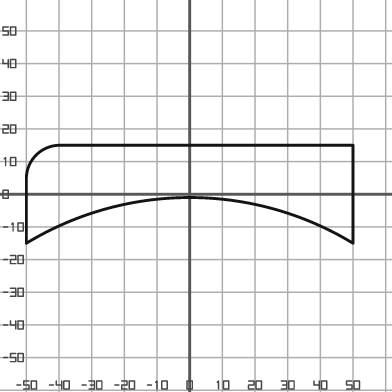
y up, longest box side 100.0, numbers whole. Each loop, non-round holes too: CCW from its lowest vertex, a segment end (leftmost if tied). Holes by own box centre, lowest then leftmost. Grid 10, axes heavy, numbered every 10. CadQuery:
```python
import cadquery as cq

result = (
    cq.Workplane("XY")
    .moveTo(-50.0, -15.0)
    .threePointArc((0.0, -1.0), (50.0, -15.0))
    .lineTo(50.0, 15.0)
    .lineTo(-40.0, 15.0)
    .threePointArc((-47.0, 12.0), (-50.0, 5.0))
    .close()
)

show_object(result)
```